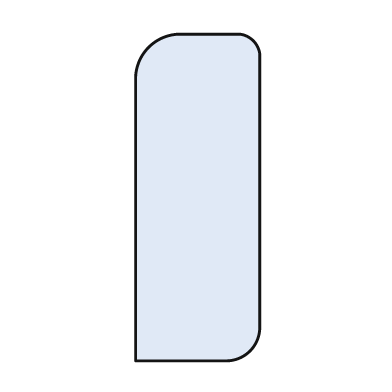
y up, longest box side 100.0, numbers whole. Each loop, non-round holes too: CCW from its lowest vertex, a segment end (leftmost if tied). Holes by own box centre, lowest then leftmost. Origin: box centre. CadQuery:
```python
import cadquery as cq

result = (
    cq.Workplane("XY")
    .moveTo(-19.0, -50.0)
    .lineTo(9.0, -50.0)
    .threePointArc((16.0, -47.0), (19.0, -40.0))
    .lineTo(19.0, 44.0)
    .threePointArc((17.0, 48.0), (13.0, 50.0))
    .lineTo(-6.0, 50.0)
    .threePointArc((-15.0, 46.0), (-19.0, 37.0))
    .close()
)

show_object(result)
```